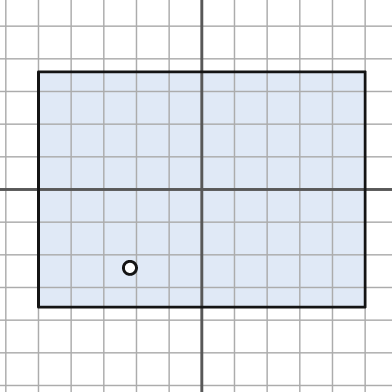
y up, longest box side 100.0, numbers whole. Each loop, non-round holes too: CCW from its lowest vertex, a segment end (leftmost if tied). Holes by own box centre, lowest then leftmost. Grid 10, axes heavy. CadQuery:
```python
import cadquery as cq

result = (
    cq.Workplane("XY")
    .moveTo(-50.0, -36.0)
    .lineTo(50.0, -36.0)
    .lineTo(50.0, 36.0)
    .lineTo(-50.0, 36.0)
    .close()
    .moveTo(-22.0, -24.0)
    .circle(2.0)
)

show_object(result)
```